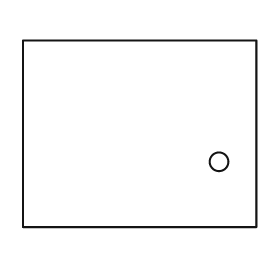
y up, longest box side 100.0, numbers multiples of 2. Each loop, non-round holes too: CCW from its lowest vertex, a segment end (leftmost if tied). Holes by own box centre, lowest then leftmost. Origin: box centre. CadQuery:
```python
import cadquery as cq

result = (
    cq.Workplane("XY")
    .moveTo(-50.0, -40.0)
    .lineTo(50.0, -40.0)
    .lineTo(50.0, 40.0)
    .lineTo(-50.0, 40.0)
    .close()
    .moveTo(34.0, -12.0)
    .circle(4.0)
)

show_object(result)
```